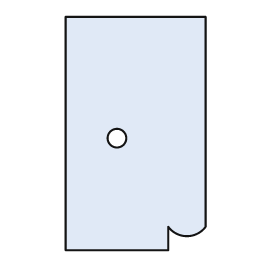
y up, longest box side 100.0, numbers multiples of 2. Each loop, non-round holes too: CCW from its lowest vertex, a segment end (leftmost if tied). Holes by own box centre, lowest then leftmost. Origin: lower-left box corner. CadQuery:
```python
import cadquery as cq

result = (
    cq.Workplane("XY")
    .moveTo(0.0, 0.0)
    .lineTo(44.0, 0.0)
    .lineTo(44.0, 10.0)
    .threePointArc((52.0, 6.0), (60.0, 10.0))
    .lineTo(60.0, 100.0)
    .lineTo(0.0, 100.0)
    .close()
    .moveTo(22.0, 48.0)
    .circle(4.0)
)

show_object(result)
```